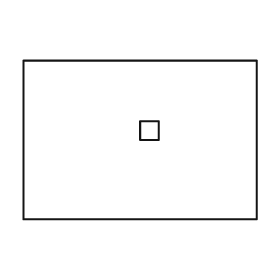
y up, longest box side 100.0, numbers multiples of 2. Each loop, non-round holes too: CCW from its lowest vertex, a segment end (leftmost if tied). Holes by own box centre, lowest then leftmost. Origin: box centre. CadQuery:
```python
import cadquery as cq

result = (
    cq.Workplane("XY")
    .moveTo(-50.0, -34.0)
    .lineTo(50.0, -34.0)
    .lineTo(50.0, 34.0)
    .lineTo(-50.0, 34.0)
    .close()
    .moveTo(0.0, 0.0)
    .lineTo(8.0, 0.0)
    .lineTo(8.0, 8.0)
    .lineTo(0.0, 8.0)
    .close()
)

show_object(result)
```